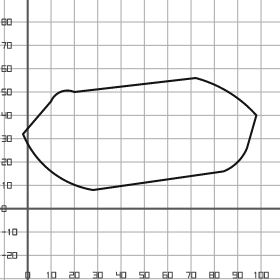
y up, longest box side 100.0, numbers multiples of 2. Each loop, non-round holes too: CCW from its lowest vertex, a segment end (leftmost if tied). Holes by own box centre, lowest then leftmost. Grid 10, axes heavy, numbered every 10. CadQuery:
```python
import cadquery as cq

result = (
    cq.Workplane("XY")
    .moveTo(28.0, 8.0)
    .lineTo(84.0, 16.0)
    .threePointArc((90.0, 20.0), (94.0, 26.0))
    .lineTo(98.0, 40.0)
    .threePointArc((86.0, 50.0), (72.0, 56.0))
    .lineTo(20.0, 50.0)
    .threePointArc((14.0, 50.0), (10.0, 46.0))
    .lineTo(-2.0, 32.0)
    .threePointArc((10.0, 16.0), (28.0, 8.0))
    .close()
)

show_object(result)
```